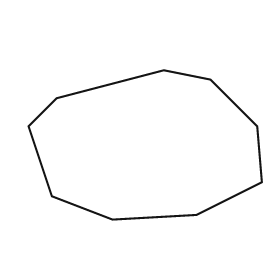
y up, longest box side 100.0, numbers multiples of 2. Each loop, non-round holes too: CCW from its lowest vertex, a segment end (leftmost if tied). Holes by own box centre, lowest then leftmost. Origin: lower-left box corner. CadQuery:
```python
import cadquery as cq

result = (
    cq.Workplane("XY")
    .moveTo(36.0, 0.0)
    .lineTo(72.0, 2.0)
    .lineTo(100.0, 16.0)
    .lineTo(98.0, 40.0)
    .lineTo(78.0, 60.0)
    .lineTo(58.0, 64.0)
    .lineTo(12.0, 52.0)
    .lineTo(0.0, 40.0)
    .lineTo(10.0, 10.0)
    .close()
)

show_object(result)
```